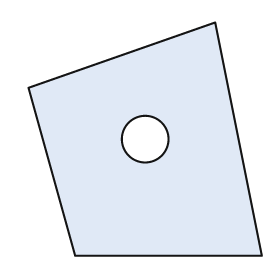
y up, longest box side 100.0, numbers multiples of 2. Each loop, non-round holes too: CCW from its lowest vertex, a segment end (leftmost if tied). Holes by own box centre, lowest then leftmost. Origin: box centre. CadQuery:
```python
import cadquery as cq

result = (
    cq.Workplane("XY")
    .moveTo(-30.0, -50.0)
    .lineTo(50.0, -50.0)
    .lineTo(30.0, 50.0)
    .lineTo(-50.0, 22.0)
    .close()
    .moveTo(0.0, 0.0)
    .circle(10.0)
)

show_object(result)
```